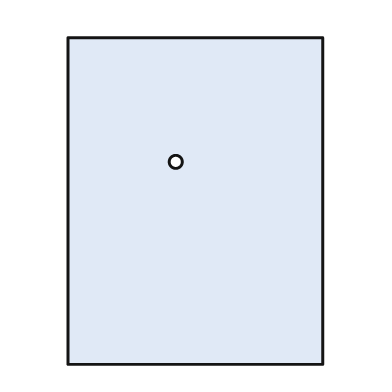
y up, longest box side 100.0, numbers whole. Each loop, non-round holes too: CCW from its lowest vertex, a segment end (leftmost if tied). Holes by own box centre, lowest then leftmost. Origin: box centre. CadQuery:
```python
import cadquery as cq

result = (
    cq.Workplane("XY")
    .moveTo(-39.0, -50.0)
    .lineTo(39.0, -50.0)
    .lineTo(39.0, 50.0)
    .lineTo(-39.0, 50.0)
    .close()
    .moveTo(-6.0, 12.0)
    .circle(2.0)
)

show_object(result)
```